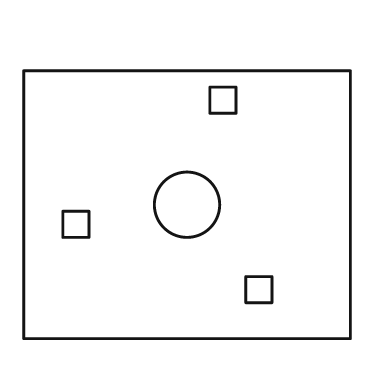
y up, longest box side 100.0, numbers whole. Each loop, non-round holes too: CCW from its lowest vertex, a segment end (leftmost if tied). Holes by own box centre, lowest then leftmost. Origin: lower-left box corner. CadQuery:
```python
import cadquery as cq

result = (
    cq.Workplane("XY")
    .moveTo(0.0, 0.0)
    .lineTo(100.0, 0.0)
    .lineTo(100.0, 82.0)
    .lineTo(0.0, 82.0)
    .close()
    .moveTo(68.0, 11.0)
    .lineTo(76.0, 11.0)
    .lineTo(76.0, 19.0)
    .lineTo(68.0, 19.0)
    .close()
    .moveTo(12.0, 31.0)
    .lineTo(20.0, 31.0)
    .lineTo(20.0, 39.0)
    .lineTo(12.0, 39.0)
    .close()
    .moveTo(50.0, 41.0)
    .circle(10.0)
    .moveTo(57.0, 69.0)
    .lineTo(65.0, 69.0)
    .lineTo(65.0, 77.0)
    .lineTo(57.0, 77.0)
    .close()
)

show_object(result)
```